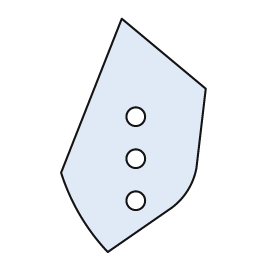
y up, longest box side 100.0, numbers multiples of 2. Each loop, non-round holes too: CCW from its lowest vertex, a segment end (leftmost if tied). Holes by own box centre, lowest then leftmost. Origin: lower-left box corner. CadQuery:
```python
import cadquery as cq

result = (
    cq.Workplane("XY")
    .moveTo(20.0, 0.0)
    .lineTo(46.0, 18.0)
    .threePointArc((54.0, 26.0), (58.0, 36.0))
    .lineTo(62.0, 70.0)
    .lineTo(26.0, 100.0)
    .lineTo(0.0, 34.0)
    .threePointArc((8.0, 16.0), (20.0, 0.0))
    .close()
    .moveTo(32.0, 22.0)
    .circle(4.0)
    .moveTo(32.0, 40.0)
    .circle(4.0)
    .moveTo(32.0, 58.0)
    .circle(4.0)
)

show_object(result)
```